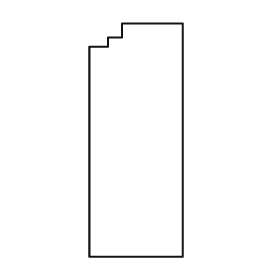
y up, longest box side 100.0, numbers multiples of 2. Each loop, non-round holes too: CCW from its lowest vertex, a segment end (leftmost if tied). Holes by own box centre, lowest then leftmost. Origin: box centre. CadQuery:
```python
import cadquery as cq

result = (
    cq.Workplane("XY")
    .moveTo(-20.0, -50.0)
    .lineTo(20.0, -50.0)
    .lineTo(20.0, 50.0)
    .lineTo(-6.0, 50.0)
    .lineTo(-6.0, 44.0)
    .lineTo(-12.0, 44.0)
    .lineTo(-12.0, 40.0)
    .lineTo(-20.0, 40.0)
    .close()
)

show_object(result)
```